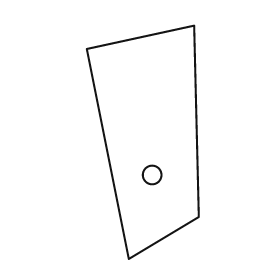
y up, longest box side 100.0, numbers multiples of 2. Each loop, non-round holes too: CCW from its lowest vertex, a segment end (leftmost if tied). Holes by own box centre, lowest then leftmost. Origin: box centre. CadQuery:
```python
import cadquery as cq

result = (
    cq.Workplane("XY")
    .moveTo(-6.0, -50.0)
    .lineTo(24.0, -32.0)
    .lineTo(22.0, 50.0)
    .lineTo(-24.0, 40.0)
    .close()
    .moveTo(4.0, -14.0)
    .circle(4.0)
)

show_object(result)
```